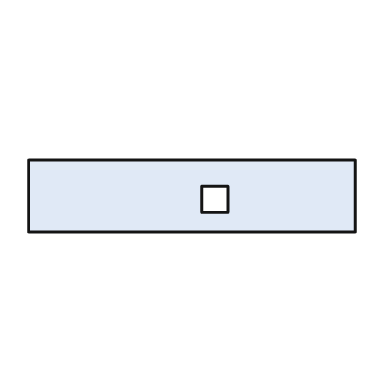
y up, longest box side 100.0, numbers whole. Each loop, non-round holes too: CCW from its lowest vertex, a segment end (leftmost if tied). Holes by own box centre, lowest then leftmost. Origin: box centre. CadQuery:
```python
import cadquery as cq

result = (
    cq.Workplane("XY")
    .moveTo(-50.0, -11.0)
    .lineTo(50.0, -11.0)
    .lineTo(50.0, 11.0)
    .lineTo(-50.0, 11.0)
    .close()
    .moveTo(3.0, -5.0)
    .lineTo(11.0, -5.0)
    .lineTo(11.0, 3.0)
    .lineTo(3.0, 3.0)
    .close()
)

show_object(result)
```